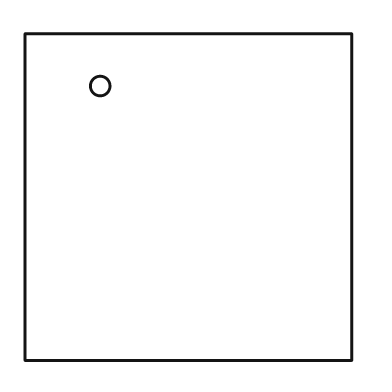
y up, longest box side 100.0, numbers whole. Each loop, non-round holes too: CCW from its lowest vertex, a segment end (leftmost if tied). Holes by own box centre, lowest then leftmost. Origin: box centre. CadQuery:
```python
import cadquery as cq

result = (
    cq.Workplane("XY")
    .moveTo(-50.0, -50.0)
    .lineTo(50.0, -50.0)
    .lineTo(50.0, 50.0)
    .lineTo(-50.0, 50.0)
    .close()
    .moveTo(-27.0, 34.0)
    .circle(3.0)
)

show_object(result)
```